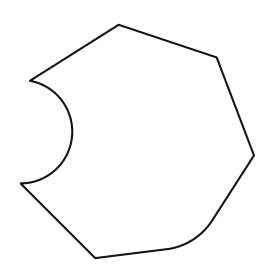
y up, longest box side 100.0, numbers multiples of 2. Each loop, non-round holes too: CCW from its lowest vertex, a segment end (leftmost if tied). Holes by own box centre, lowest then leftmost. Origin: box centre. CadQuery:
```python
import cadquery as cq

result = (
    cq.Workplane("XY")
    .moveTo(-18.0, -50.0)
    .lineTo(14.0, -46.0)
    .threePointArc((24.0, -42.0), (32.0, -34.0))
    .lineTo(50.0, -6.0)
    .lineTo(34.0, 36.0)
    .lineTo(-8.0, 50.0)
    .lineTo(-46.0, 26.0)
    .threePointArc((-28.0, 2.0), (-50.0, -18.0))
    .close()
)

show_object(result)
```